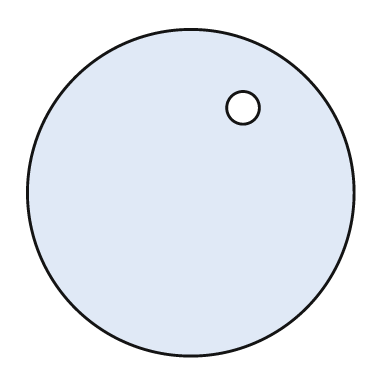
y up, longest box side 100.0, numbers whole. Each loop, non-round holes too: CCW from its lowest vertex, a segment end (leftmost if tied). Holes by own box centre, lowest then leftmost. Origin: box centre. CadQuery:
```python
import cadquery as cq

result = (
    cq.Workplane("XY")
    .moveTo(0.0, 0.0)
    .circle(50.0)
    .moveTo(16.0, 26.0)
    .circle(5.0)
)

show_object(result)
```